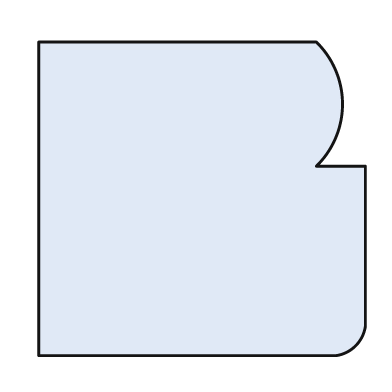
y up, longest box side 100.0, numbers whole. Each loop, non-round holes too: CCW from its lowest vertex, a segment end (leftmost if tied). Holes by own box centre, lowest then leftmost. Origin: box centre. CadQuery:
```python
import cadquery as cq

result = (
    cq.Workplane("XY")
    .moveTo(-50.0, -48.0)
    .lineTo(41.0, -48.0)
    .threePointArc((47.0, -45.0), (50.0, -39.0))
    .lineTo(50.0, 10.0)
    .lineTo(35.0, 10.0)
    .threePointArc((43.0, 29.0), (35.0, 48.0))
    .lineTo(-50.0, 48.0)
    .close()
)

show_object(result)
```